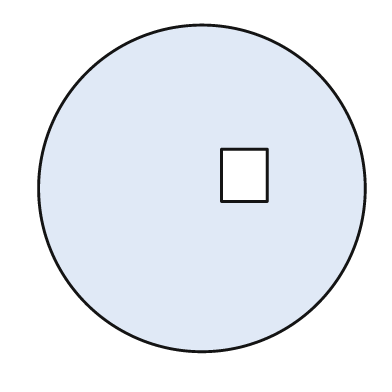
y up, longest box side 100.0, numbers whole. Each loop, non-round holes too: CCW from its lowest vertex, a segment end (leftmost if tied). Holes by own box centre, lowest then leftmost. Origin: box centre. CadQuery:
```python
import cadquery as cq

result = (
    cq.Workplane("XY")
    .moveTo(0.0, 0.0)
    .circle(50.0)
    .moveTo(6.0, -4.0)
    .lineTo(20.0, -4.0)
    .lineTo(20.0, 12.0)
    .lineTo(6.0, 12.0)
    .close()
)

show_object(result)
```